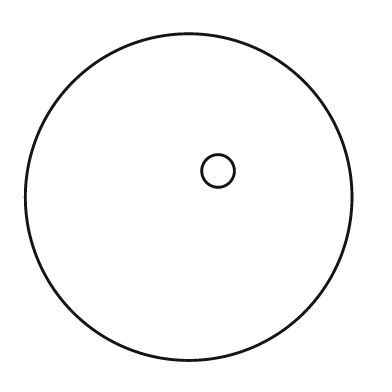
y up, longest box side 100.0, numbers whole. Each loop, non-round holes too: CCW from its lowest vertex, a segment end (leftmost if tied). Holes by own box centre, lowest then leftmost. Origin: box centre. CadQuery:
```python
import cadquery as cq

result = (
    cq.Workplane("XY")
    .moveTo(0.0, 0.0)
    .circle(50.0)
    .moveTo(9.0, 8.0)
    .circle(5.0)
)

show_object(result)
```